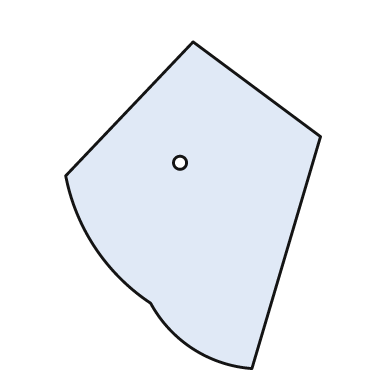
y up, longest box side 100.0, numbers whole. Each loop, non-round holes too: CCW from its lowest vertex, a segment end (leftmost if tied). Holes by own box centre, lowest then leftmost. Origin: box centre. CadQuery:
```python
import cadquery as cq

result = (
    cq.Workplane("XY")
    .moveTo(18.0, -50.0)
    .lineTo(39.0, 21.0)
    .lineTo(0.0, 50.0)
    .lineTo(-39.0, 9.0)
    .threePointArc((-30.0, -13.0), (-13.0, -30.0))
    .threePointArc((0.0, -44.0), (18.0, -50.0))
    .close()
    .moveTo(-4.0, 13.0)
    .circle(2.0)
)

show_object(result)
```